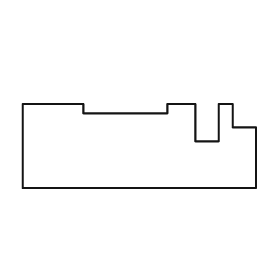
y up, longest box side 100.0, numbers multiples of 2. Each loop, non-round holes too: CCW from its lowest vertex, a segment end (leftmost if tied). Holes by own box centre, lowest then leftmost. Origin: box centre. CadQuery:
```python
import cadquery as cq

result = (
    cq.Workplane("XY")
    .moveTo(-50.0, -18.0)
    .lineTo(50.0, -18.0)
    .lineTo(50.0, 8.0)
    .lineTo(40.0, 8.0)
    .lineTo(40.0, 18.0)
    .lineTo(34.0, 18.0)
    .lineTo(34.0, 2.0)
    .lineTo(24.0, 2.0)
    .lineTo(24.0, 18.0)
    .lineTo(12.0, 18.0)
    .lineTo(12.0, 14.0)
    .lineTo(-24.0, 14.0)
    .lineTo(-24.0, 18.0)
    .lineTo(-50.0, 18.0)
    .close()
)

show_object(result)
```